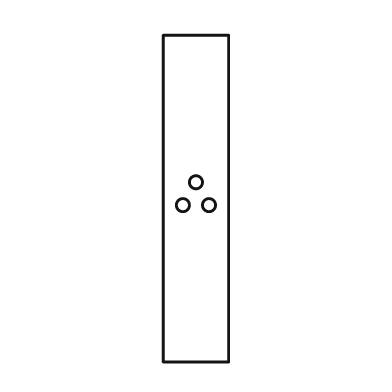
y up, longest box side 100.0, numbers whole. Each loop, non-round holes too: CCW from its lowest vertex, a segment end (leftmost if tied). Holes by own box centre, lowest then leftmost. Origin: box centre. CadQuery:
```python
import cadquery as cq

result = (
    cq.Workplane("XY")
    .moveTo(-10.0, -50.0)
    .lineTo(10.0, -50.0)
    .lineTo(10.0, 50.0)
    .lineTo(-10.0, 50.0)
    .close()
    .moveTo(-4.0, -2.0)
    .circle(2.0)
    .moveTo(4.0, -2.0)
    .circle(2.0)
    .moveTo(0.0, 5.0)
    .circle(2.0)
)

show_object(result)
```